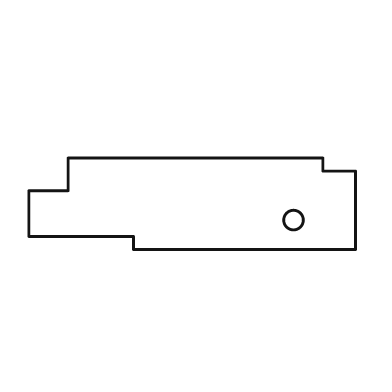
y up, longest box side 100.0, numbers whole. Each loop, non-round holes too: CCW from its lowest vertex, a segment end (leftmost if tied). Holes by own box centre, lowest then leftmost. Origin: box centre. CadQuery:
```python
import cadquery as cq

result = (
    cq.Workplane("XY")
    .moveTo(-18.0, -14.0)
    .lineTo(50.0, -14.0)
    .lineTo(50.0, 10.0)
    .lineTo(40.0, 10.0)
    .lineTo(40.0, 14.0)
    .lineTo(-38.0, 14.0)
    .lineTo(-38.0, 4.0)
    .lineTo(-50.0, 4.0)
    .lineTo(-50.0, -10.0)
    .lineTo(-18.0, -10.0)
    .close()
    .moveTo(31.0, -5.0)
    .circle(3.0)
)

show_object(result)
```